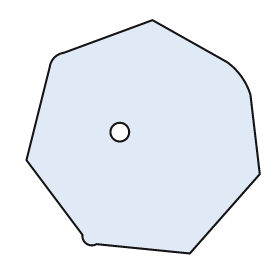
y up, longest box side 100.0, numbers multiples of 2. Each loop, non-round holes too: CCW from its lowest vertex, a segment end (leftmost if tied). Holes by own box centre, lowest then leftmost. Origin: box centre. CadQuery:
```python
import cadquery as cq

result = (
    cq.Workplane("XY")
    .moveTo(20.0, -50.0)
    .lineTo(50.0, -16.0)
    .lineTo(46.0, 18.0)
    .threePointArc((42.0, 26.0), (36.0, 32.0))
    .lineTo(4.0, 50.0)
    .lineTo(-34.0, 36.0)
    .threePointArc((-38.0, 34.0), (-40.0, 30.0))
    .lineTo(-50.0, -10.0)
    .lineTo(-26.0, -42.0)
    .threePointArc((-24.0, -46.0), (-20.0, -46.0))
    .close()
    .moveTo(-10.0, 2.0)
    .circle(4.0)
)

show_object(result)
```